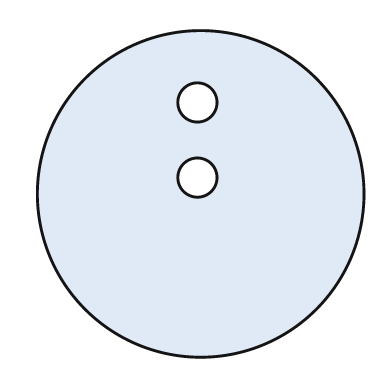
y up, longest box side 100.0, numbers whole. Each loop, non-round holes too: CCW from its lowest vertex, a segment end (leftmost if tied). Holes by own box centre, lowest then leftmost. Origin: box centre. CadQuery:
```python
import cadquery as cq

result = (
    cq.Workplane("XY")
    .moveTo(0.0, 0.0)
    .circle(50.0)
    .moveTo(-1.0, 5.0)
    .circle(6.0)
    .moveTo(-1.0, 28.0)
    .circle(6.0)
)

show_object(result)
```